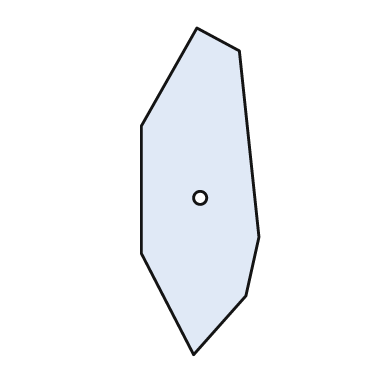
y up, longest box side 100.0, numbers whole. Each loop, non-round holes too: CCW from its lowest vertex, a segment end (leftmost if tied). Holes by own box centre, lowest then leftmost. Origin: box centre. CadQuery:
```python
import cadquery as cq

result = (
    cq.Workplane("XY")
    .moveTo(-2.0, -50.0)
    .lineTo(14.0, -32.0)
    .lineTo(18.0, -14.0)
    .lineTo(12.0, 43.0)
    .lineTo(-1.0, 50.0)
    .lineTo(-18.0, 20.0)
    .lineTo(-18.0, -19.0)
    .close()
    .moveTo(0.0, -2.0)
    .circle(2.0)
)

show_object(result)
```